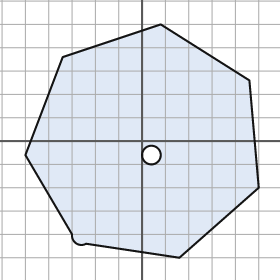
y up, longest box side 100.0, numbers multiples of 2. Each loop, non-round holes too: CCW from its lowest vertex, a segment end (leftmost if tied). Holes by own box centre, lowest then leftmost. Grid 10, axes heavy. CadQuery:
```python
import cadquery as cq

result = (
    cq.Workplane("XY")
    .moveTo(16.0, -50.0)
    .lineTo(50.0, -20.0)
    .lineTo(46.0, 26.0)
    .lineTo(8.0, 50.0)
    .lineTo(-34.0, 36.0)
    .lineTo(-50.0, -6.0)
    .lineTo(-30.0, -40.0)
    .threePointArc((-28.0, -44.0), (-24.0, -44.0))
    .close()
    .moveTo(4.0, -6.0)
    .circle(4.0)
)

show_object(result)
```